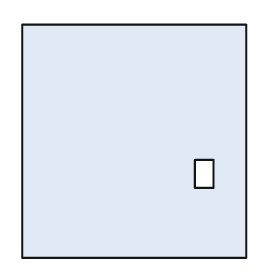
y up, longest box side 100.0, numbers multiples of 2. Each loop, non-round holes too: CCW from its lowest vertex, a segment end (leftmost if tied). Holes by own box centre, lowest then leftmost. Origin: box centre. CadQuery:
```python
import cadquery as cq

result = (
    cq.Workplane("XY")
    .moveTo(-48.0, -50.0)
    .lineTo(48.0, -50.0)
    .lineTo(48.0, 50.0)
    .lineTo(-48.0, 50.0)
    .close()
    .moveTo(26.0, -20.0)
    .lineTo(34.0, -20.0)
    .lineTo(34.0, -8.0)
    .lineTo(26.0, -8.0)
    .close()
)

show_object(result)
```